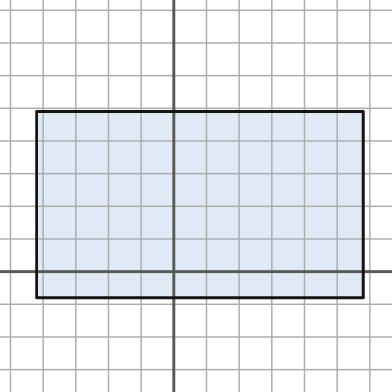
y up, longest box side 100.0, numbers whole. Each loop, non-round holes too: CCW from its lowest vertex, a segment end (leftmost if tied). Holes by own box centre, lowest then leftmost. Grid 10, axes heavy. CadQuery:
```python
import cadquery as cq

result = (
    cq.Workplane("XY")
    .moveTo(-42.0, -8.0)
    .lineTo(58.0, -8.0)
    .lineTo(58.0, 49.0)
    .lineTo(-42.0, 49.0)
    .close()
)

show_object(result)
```